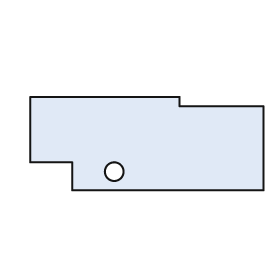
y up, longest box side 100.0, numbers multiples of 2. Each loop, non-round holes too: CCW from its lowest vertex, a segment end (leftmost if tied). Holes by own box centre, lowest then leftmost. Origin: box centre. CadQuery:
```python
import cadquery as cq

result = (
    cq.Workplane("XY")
    .moveTo(-32.0, -20.0)
    .lineTo(50.0, -20.0)
    .lineTo(50.0, 16.0)
    .lineTo(14.0, 16.0)
    .lineTo(14.0, 20.0)
    .lineTo(-50.0, 20.0)
    .lineTo(-50.0, -8.0)
    .lineTo(-32.0, -8.0)
    .close()
    .moveTo(-14.0, -12.0)
    .circle(4.0)
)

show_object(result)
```